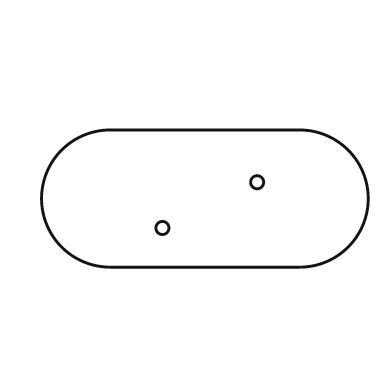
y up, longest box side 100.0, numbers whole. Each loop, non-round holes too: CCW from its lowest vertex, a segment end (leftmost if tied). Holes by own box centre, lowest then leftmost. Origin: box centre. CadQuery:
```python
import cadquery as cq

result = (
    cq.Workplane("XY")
    .moveTo(-29.0, -21.0)
    .lineTo(29.0, -21.0)
    .threePointArc((50.0, 0.0), (29.0, 21.0))
    .lineTo(-29.0, 21.0)
    .threePointArc((-50.0, 0.0), (-29.0, -21.0))
    .close()
    .moveTo(-13.0, -9.0)
    .circle(2.0)
    .moveTo(16.0, 5.0)
    .circle(2.0)
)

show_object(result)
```